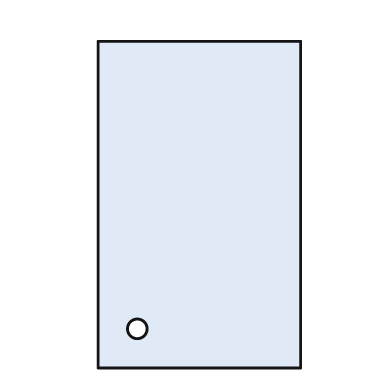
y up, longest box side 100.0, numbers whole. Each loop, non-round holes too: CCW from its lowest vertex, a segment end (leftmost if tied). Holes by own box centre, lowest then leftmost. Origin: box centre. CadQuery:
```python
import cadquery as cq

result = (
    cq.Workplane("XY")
    .moveTo(-31.0, -50.0)
    .lineTo(31.0, -50.0)
    .lineTo(31.0, 50.0)
    .lineTo(-31.0, 50.0)
    .close()
    .moveTo(-19.0, -38.0)
    .circle(3.0)
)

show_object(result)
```